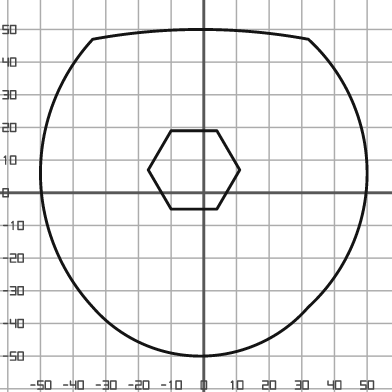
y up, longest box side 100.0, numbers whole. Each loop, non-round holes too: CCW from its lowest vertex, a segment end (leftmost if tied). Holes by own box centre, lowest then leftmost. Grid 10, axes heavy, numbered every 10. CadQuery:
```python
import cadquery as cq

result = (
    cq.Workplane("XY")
    .moveTo(-34.0, -35.0)
    .threePointArc((-1.0, -50.0), (32.0, -35.0))
    .threePointArc((50.0, 6.0), (32.0, 47.0))
    .threePointArc((-1.0, 50.0), (-34.0, 47.0))
    .threePointArc((-50.0, 6.0), (-34.0, -35.0))
    .close()
    .moveTo(-10.0, -5.0)
    .lineTo(4.0, -5.0)
    .lineTo(11.0, 7.0)
    .lineTo(4.0, 19.0)
    .lineTo(-10.0, 19.0)
    .lineTo(-17.0, 7.0)
    .close()
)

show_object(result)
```